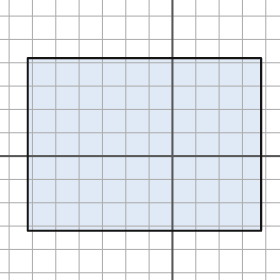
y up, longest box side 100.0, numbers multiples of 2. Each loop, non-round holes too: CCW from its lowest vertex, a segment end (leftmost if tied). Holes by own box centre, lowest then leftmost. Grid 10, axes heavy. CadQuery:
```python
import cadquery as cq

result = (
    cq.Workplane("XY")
    .moveTo(-62.0, -32.0)
    .lineTo(38.0, -32.0)
    .lineTo(38.0, 42.0)
    .lineTo(-62.0, 42.0)
    .close()
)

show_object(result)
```